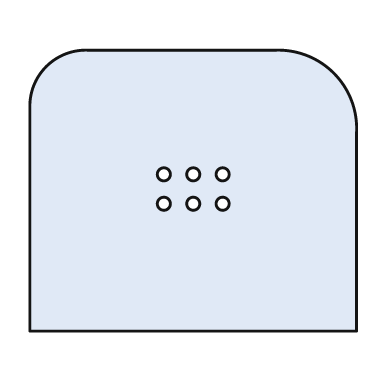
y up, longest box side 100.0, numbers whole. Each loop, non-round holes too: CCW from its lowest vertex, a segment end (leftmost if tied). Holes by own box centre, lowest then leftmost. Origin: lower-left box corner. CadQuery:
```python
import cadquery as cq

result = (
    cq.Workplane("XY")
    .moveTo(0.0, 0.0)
    .lineTo(100.0, 0.0)
    .lineTo(100.0, 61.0)
    .threePointArc((93.0, 79.0), (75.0, 86.0))
    .lineTo(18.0, 86.0)
    .threePointArc((5.0, 81.0), (0.0, 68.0))
    .close()
    .moveTo(41.0, 39.0)
    .circle(2.0)
    .moveTo(50.0, 39.0)
    .circle(2.0)
    .moveTo(59.0, 39.0)
    .circle(2.0)
    .moveTo(41.0, 48.0)
    .circle(2.0)
    .moveTo(50.0, 48.0)
    .circle(2.0)
    .moveTo(59.0, 48.0)
    .circle(2.0)
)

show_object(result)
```